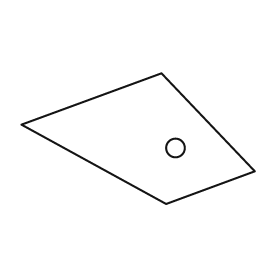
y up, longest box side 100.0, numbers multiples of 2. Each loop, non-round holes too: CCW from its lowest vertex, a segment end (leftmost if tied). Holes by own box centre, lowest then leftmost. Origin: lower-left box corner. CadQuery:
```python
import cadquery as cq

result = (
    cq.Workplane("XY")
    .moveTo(62.0, 0.0)
    .lineTo(100.0, 14.0)
    .lineTo(60.0, 56.0)
    .lineTo(0.0, 34.0)
    .close()
    .moveTo(66.0, 24.0)
    .circle(4.0)
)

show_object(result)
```